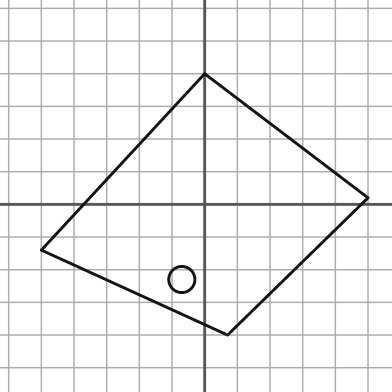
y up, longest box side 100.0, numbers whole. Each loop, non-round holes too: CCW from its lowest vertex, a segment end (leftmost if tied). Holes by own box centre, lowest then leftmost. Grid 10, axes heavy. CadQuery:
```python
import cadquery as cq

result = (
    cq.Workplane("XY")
    .moveTo(7.0, -40.0)
    .lineTo(50.0, 2.0)
    .lineTo(0.0, 40.0)
    .lineTo(-50.0, -14.0)
    .close()
    .moveTo(-7.0, -23.0)
    .circle(4.0)
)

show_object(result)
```